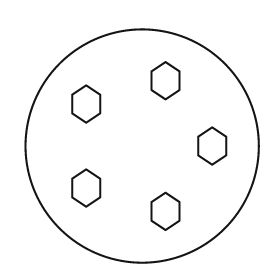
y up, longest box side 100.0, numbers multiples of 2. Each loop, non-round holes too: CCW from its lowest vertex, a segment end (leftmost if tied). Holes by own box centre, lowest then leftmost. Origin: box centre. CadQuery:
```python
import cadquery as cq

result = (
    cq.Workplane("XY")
    .moveTo(0.0, 0.0)
    .circle(50.0)
    .moveTo(10.0, -36.0)
    .lineTo(16.0, -32.0)
    .lineTo(16.0, -24.0)
    .lineTo(10.0, -20.0)
    .lineTo(4.0, -24.0)
    .lineTo(4.0, -32.0)
    .close()
    .moveTo(-24.0, -26.0)
    .lineTo(-18.0, -22.0)
    .lineTo(-18.0, -14.0)
    .lineTo(-24.0, -10.0)
    .lineTo(-30.0, -14.0)
    .lineTo(-30.0, -22.0)
    .close()
    .moveTo(30.0, -8.0)
    .lineTo(36.0, -4.0)
    .lineTo(36.0, 4.0)
    .lineTo(30.0, 8.0)
    .lineTo(24.0, 4.0)
    .lineTo(24.0, -4.0)
    .close()
    .moveTo(-24.0, 10.0)
    .lineTo(-18.0, 14.0)
    .lineTo(-18.0, 22.0)
    .lineTo(-24.0, 26.0)
    .lineTo(-30.0, 22.0)
    .lineTo(-30.0, 14.0)
    .close()
    .moveTo(10.0, 20.0)
    .lineTo(16.0, 24.0)
    .lineTo(16.0, 32.0)
    .lineTo(10.0, 36.0)
    .lineTo(4.0, 32.0)
    .lineTo(4.0, 24.0)
    .close()
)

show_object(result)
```